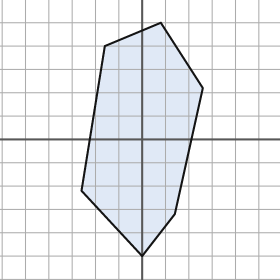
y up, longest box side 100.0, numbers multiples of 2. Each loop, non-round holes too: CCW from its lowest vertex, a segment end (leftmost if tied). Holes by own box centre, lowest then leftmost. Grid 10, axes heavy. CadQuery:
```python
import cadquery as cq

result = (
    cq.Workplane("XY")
    .moveTo(0.0, -50.0)
    .lineTo(14.0, -32.0)
    .lineTo(26.0, 22.0)
    .lineTo(8.0, 50.0)
    .lineTo(-16.0, 40.0)
    .lineTo(-26.0, -22.0)
    .close()
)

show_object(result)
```